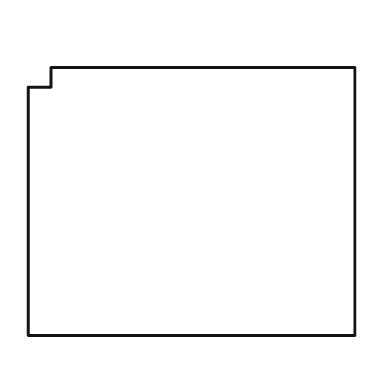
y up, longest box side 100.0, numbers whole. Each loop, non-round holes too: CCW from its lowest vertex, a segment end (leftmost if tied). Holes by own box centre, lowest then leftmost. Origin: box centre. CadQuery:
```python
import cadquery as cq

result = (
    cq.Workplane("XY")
    .moveTo(-50.0, -41.0)
    .lineTo(50.0, -41.0)
    .lineTo(50.0, 41.0)
    .lineTo(-43.0, 41.0)
    .lineTo(-43.0, 35.0)
    .lineTo(-50.0, 35.0)
    .close()
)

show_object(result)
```